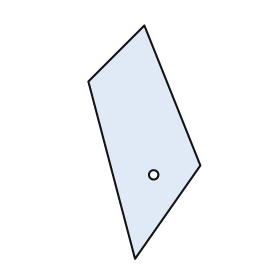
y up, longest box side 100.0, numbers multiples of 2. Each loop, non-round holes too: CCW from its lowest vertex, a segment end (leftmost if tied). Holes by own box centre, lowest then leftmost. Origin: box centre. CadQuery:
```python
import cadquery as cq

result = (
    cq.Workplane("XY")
    .moveTo(-4.0, -50.0)
    .lineTo(24.0, -10.0)
    .lineTo(0.0, 50.0)
    .lineTo(-24.0, 26.0)
    .close()
    .moveTo(4.0, -14.0)
    .circle(2.0)
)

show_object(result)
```